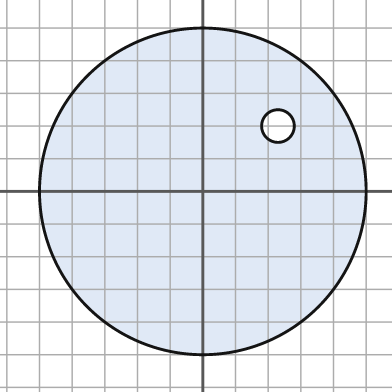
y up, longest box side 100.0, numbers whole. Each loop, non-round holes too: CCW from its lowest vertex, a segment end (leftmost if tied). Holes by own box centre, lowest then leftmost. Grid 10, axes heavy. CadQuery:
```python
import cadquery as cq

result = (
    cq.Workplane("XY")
    .moveTo(0.0, 0.0)
    .circle(50.0)
    .moveTo(23.0, 20.0)
    .circle(5.0)
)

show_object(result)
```